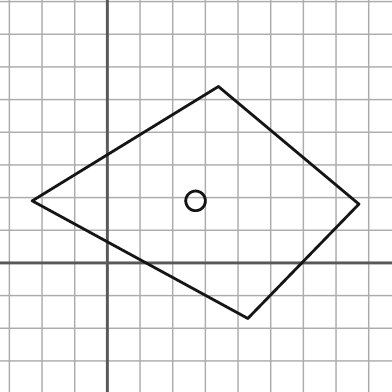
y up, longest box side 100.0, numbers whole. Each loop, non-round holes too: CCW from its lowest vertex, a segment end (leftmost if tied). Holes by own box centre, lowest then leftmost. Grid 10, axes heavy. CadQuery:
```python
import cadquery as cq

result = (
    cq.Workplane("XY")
    .moveTo(43.0, -17.0)
    .lineTo(77.0, 18.0)
    .lineTo(34.0, 54.0)
    .lineTo(-23.0, 19.0)
    .close()
    .moveTo(27.0, 19.0)
    .circle(3.0)
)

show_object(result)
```